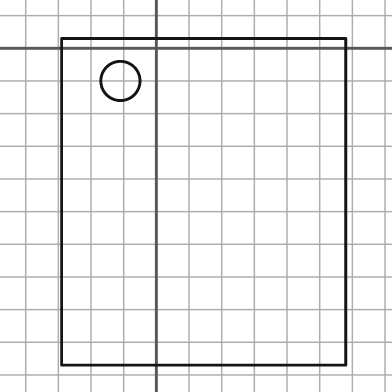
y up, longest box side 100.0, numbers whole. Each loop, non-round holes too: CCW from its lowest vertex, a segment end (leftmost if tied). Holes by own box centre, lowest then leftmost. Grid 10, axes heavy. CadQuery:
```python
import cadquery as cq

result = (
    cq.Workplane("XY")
    .moveTo(-29.0, -97.0)
    .lineTo(58.0, -97.0)
    .lineTo(58.0, 3.0)
    .lineTo(-29.0, 3.0)
    .close()
    .moveTo(-11.0, -10.0)
    .circle(6.0)
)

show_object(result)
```